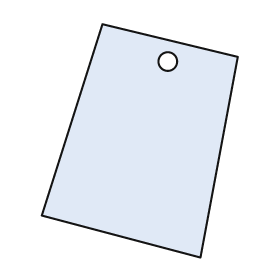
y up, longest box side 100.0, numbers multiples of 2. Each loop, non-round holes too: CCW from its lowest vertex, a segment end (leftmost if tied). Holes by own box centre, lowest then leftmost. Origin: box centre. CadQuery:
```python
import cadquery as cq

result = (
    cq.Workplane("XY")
    .moveTo(26.0, -50.0)
    .lineTo(42.0, 36.0)
    .lineTo(-16.0, 50.0)
    .lineTo(-42.0, -32.0)
    .close()
    .moveTo(12.0, 34.0)
    .circle(4.0)
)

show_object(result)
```